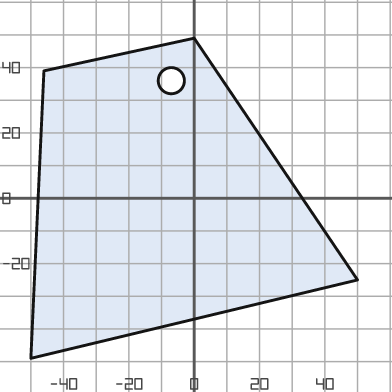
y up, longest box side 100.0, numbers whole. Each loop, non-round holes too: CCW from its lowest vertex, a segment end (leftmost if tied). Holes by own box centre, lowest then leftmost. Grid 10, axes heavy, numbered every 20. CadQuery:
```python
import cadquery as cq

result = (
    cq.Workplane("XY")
    .moveTo(-50.0, -49.0)
    .lineTo(50.0, -25.0)
    .lineTo(0.0, 49.0)
    .lineTo(-46.0, 39.0)
    .close()
    .moveTo(-7.0, 36.0)
    .circle(4.0)
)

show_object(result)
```